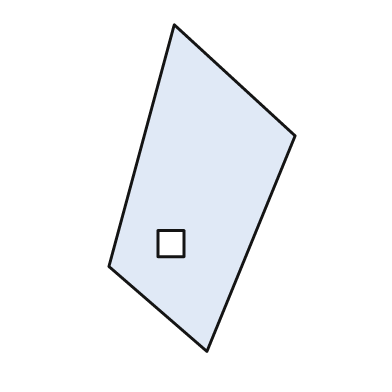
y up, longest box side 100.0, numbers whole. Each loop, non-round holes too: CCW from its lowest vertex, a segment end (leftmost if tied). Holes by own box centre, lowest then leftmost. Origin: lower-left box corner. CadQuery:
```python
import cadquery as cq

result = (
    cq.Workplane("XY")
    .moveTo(30.0, 0.0)
    .lineTo(57.0, 66.0)
    .lineTo(20.0, 100.0)
    .lineTo(0.0, 26.0)
    .close()
    .moveTo(15.0, 29.0)
    .lineTo(23.0, 29.0)
    .lineTo(23.0, 37.0)
    .lineTo(15.0, 37.0)
    .close()
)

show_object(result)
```